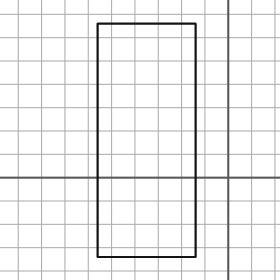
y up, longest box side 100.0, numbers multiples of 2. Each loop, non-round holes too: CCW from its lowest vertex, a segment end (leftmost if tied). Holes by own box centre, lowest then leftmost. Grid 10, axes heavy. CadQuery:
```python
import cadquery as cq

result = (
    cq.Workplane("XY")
    .moveTo(-56.0, -34.0)
    .lineTo(-14.0, -34.0)
    .lineTo(-14.0, 66.0)
    .lineTo(-56.0, 66.0)
    .close()
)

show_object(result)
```